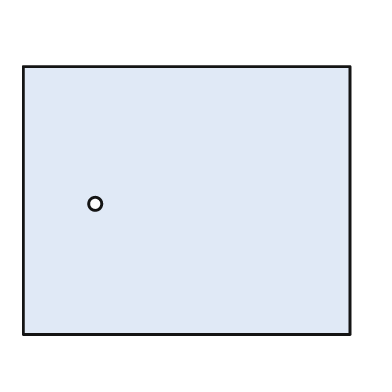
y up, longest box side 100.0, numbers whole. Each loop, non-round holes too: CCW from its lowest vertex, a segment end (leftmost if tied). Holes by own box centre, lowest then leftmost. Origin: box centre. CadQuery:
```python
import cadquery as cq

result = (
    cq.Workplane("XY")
    .moveTo(-50.0, -41.0)
    .lineTo(50.0, -41.0)
    .lineTo(50.0, 41.0)
    .lineTo(-50.0, 41.0)
    .close()
    .moveTo(-28.0, -1.0)
    .circle(2.0)
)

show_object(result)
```